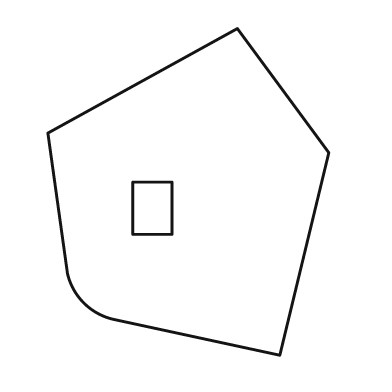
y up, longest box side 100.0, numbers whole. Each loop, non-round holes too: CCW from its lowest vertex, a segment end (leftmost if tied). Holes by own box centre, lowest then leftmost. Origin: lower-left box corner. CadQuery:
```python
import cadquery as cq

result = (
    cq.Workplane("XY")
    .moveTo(71.0, 0.0)
    .lineTo(86.0, 62.0)
    .lineTo(58.0, 100.0)
    .lineTo(0.0, 68.0)
    .lineTo(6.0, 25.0)
    .threePointArc((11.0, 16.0), (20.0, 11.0))
    .close()
    .moveTo(26.0, 37.0)
    .lineTo(38.0, 37.0)
    .lineTo(38.0, 53.0)
    .lineTo(26.0, 53.0)
    .close()
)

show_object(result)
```